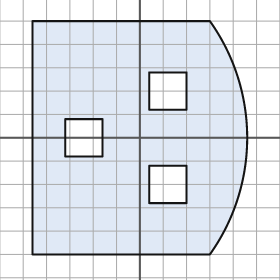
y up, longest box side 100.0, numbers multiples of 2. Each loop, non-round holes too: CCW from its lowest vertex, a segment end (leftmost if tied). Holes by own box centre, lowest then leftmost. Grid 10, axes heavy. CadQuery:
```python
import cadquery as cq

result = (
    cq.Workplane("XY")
    .moveTo(-46.0, -50.0)
    .lineTo(30.0, -50.0)
    .threePointArc((46.0, 0.0), (30.0, 50.0))
    .lineTo(-46.0, 50.0)
    .close()
    .moveTo(4.0, -28.0)
    .lineTo(20.0, -28.0)
    .lineTo(20.0, -12.0)
    .lineTo(4.0, -12.0)
    .close()
    .moveTo(-32.0, -8.0)
    .lineTo(-16.0, -8.0)
    .lineTo(-16.0, 8.0)
    .lineTo(-32.0, 8.0)
    .close()
    .moveTo(4.0, 12.0)
    .lineTo(20.0, 12.0)
    .lineTo(20.0, 28.0)
    .lineTo(4.0, 28.0)
    .close()
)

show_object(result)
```